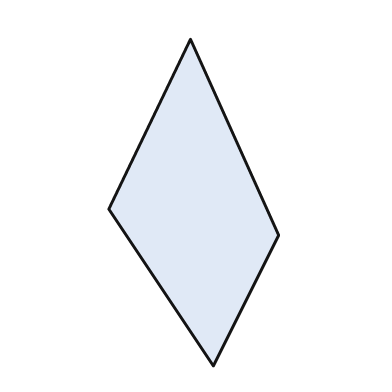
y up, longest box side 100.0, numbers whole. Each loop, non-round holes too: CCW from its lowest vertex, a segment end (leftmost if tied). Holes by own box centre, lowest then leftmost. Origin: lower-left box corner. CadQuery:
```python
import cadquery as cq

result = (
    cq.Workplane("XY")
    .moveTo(32.0, 0.0)
    .lineTo(52.0, 40.0)
    .lineTo(25.0, 100.0)
    .lineTo(0.0, 48.0)
    .close()
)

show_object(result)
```